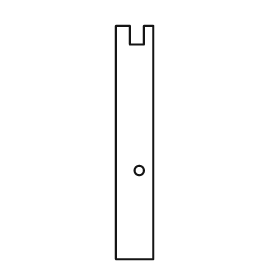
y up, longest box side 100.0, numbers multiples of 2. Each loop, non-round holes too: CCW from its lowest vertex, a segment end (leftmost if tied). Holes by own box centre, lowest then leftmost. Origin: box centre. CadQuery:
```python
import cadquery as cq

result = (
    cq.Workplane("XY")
    .moveTo(-8.0, -50.0)
    .lineTo(8.0, -50.0)
    .lineTo(8.0, 50.0)
    .lineTo(4.0, 50.0)
    .lineTo(4.0, 42.0)
    .lineTo(-2.0, 42.0)
    .lineTo(-2.0, 50.0)
    .lineTo(-8.0, 50.0)
    .close()
    .moveTo(2.0, -12.0)
    .circle(2.0)
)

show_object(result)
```